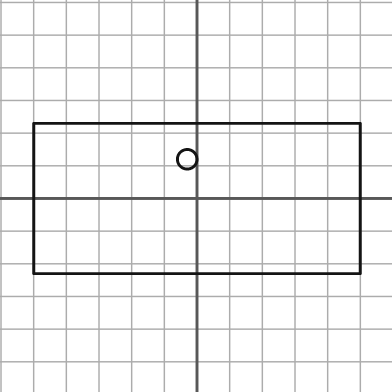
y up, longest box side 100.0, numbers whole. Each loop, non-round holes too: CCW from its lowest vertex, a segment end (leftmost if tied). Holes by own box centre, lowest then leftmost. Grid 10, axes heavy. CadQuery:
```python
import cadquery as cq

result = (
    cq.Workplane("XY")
    .moveTo(-50.0, -23.0)
    .lineTo(50.0, -23.0)
    .lineTo(50.0, 23.0)
    .lineTo(-50.0, 23.0)
    .close()
    .moveTo(-3.0, 12.0)
    .circle(3.0)
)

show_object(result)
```